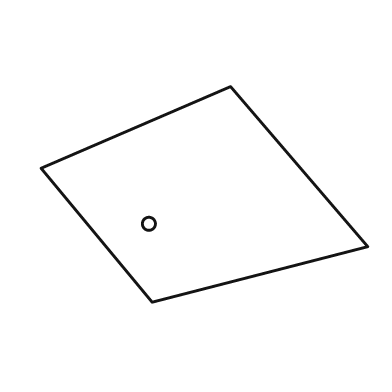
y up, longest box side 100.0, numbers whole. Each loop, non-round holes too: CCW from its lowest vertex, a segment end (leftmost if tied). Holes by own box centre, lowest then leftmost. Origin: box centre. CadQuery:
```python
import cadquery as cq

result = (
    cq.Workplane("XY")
    .moveTo(-16.0, -33.0)
    .lineTo(50.0, -16.0)
    .lineTo(8.0, 33.0)
    .lineTo(-50.0, 8.0)
    .close()
    .moveTo(-17.0, -9.0)
    .circle(2.0)
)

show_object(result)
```